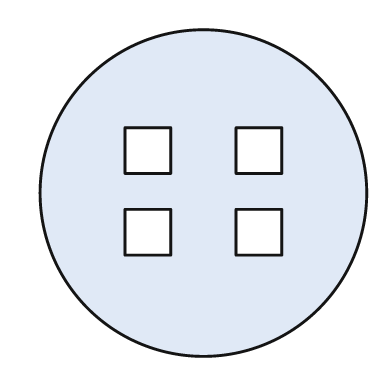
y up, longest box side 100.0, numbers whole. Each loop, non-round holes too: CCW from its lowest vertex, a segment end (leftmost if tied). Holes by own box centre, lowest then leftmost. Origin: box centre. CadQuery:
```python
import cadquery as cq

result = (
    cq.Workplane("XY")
    .moveTo(0.0, 0.0)
    .circle(50.0)
    .moveTo(-24.0, -19.0)
    .lineTo(-10.0, -19.0)
    .lineTo(-10.0, -5.0)
    .lineTo(-24.0, -5.0)
    .close()
    .moveTo(10.0, -19.0)
    .lineTo(24.0, -19.0)
    .lineTo(24.0, -5.0)
    .lineTo(10.0, -5.0)
    .close()
    .moveTo(-24.0, 6.0)
    .lineTo(-10.0, 6.0)
    .lineTo(-10.0, 20.0)
    .lineTo(-24.0, 20.0)
    .close()
    .moveTo(10.0, 6.0)
    .lineTo(24.0, 6.0)
    .lineTo(24.0, 20.0)
    .lineTo(10.0, 20.0)
    .close()
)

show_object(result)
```